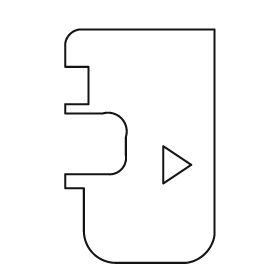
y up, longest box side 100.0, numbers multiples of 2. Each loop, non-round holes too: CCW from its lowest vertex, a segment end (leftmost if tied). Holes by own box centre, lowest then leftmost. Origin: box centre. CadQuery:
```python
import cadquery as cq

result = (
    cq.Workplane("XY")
    .moveTo(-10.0, -50.0)
    .lineTo(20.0, -50.0)
    .threePointArc((28.0, -46.0), (32.0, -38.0))
    .lineTo(32.0, 50.0)
    .lineTo(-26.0, 50.0)
    .threePointArc((-30.0, 48.0), (-32.0, 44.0))
    .lineTo(-32.0, 34.0)
    .lineTo(-22.0, 34.0)
    .lineTo(-22.0, 18.0)
    .lineTo(-32.0, 18.0)
    .lineTo(-32.0, 14.0)
    .lineTo(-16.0, 14.0)
    .threePointArc((-8.0, 12.0), (-6.0, 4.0))
    .lineTo(-6.0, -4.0)
    .threePointArc((-8.0, -10.0), (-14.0, -12.0))
    .lineTo(-32.0, -12.0)
    .lineTo(-32.0, -18.0)
    .lineTo(-24.0, -18.0)
    .lineTo(-24.0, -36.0)
    .threePointArc((-20.0, -46.0), (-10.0, -50.0))
    .close()
    .moveTo(10.0, -16.0)
    .lineTo(22.0, -8.0)
    .lineTo(10.0, 0.0)
    .close()
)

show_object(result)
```